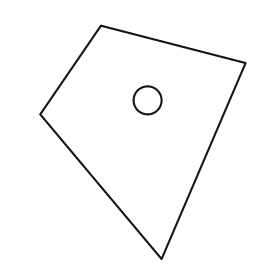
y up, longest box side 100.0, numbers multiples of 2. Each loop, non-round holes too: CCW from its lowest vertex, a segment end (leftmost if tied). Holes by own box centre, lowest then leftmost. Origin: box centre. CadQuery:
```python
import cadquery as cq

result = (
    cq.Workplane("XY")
    .moveTo(8.0, -50.0)
    .lineTo(44.0, 34.0)
    .lineTo(-18.0, 50.0)
    .lineTo(-44.0, 12.0)
    .close()
    .moveTo(2.0, 18.0)
    .circle(6.0)
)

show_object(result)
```